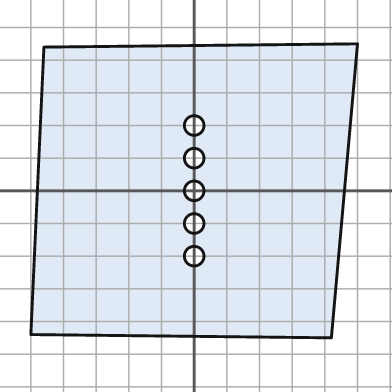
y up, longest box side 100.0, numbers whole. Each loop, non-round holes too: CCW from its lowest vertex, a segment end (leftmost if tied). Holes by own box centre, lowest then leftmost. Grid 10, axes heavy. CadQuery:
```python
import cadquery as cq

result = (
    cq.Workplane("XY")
    .moveTo(42.0, -45.0)
    .lineTo(50.0, 45.0)
    .lineTo(-46.0, 44.0)
    .lineTo(-50.0, -44.0)
    .close()
    .moveTo(0.0, -20.0)
    .circle(3.0)
    .moveTo(0.0, -10.0)
    .circle(3.0)
    .moveTo(0.0, 0.0)
    .circle(3.0)
    .moveTo(0.0, 10.0)
    .circle(3.0)
    .moveTo(0.0, 20.0)
    .circle(3.0)
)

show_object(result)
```